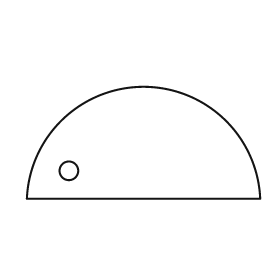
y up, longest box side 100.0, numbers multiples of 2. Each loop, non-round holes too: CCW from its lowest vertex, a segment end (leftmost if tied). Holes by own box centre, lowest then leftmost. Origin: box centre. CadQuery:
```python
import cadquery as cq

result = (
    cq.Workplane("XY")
    .moveTo(-50.0, -24.0)
    .lineTo(50.0, -24.0)
    .threePointArc((0.0, 24.0), (-50.0, -24.0))
    .close()
    .moveTo(-32.0, -12.0)
    .circle(4.0)
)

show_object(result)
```